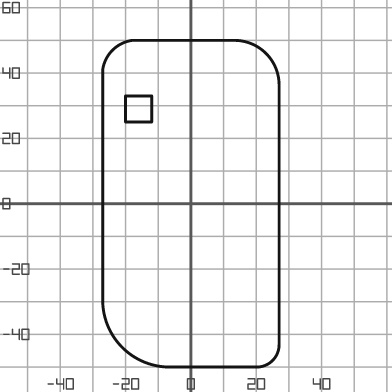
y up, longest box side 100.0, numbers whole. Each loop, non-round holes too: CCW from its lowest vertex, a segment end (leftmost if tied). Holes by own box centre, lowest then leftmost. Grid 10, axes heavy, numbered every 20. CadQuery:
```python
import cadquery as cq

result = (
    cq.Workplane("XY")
    .moveTo(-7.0, -50.0)
    .lineTo(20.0, -50.0)
    .threePointArc((25.0, -48.0), (27.0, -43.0))
    .lineTo(27.0, 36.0)
    .threePointArc((23.0, 46.0), (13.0, 50.0))
    .lineTo(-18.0, 50.0)
    .threePointArc((-24.0, 47.0), (-27.0, 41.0))
    .lineTo(-27.0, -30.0)
    .threePointArc((-21.0, -44.0), (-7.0, -50.0))
    .close()
    .moveTo(-20.0, 25.0)
    .lineTo(-12.0, 25.0)
    .lineTo(-12.0, 33.0)
    .lineTo(-20.0, 33.0)
    .close()
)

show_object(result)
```